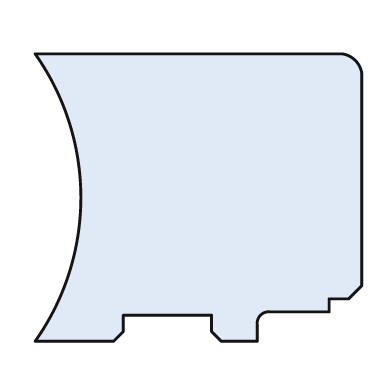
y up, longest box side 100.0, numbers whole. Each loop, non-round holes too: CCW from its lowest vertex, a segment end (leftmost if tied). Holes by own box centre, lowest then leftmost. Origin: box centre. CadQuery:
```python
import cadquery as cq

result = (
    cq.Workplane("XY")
    .moveTo(-50.0, -44.0)
    .lineTo(-26.0, -44.0)
    .lineTo(-23.0, -41.0)
    .lineTo(-23.0, -36.0)
    .lineTo(4.0, -36.0)
    .lineTo(4.0, -41.0)
    .lineTo(7.0, -44.0)
    .lineTo(18.0, -44.0)
    .lineTo(18.0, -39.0)
    .threePointArc((19.0, -36.0), (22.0, -35.0))
    .lineTo(40.0, -35.0)
    .lineTo(40.0, -31.0)
    .lineTo(46.0, -31.0)
    .lineTo(50.0, -27.0)
    .lineTo(50.0, 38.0)
    .threePointArc((48.0, 42.0), (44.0, 44.0))
    .lineTo(-50.0, 44.0)
    .threePointArc((-36.0, 0.0), (-50.0, -44.0))
    .close()
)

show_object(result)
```